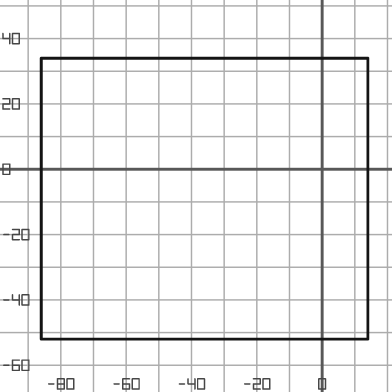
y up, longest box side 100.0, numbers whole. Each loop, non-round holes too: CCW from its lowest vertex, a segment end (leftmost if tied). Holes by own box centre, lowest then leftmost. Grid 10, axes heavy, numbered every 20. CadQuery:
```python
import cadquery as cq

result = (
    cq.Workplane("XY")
    .moveTo(-86.0, -52.0)
    .lineTo(14.0, -52.0)
    .lineTo(14.0, 34.0)
    .lineTo(-86.0, 34.0)
    .close()
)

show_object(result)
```